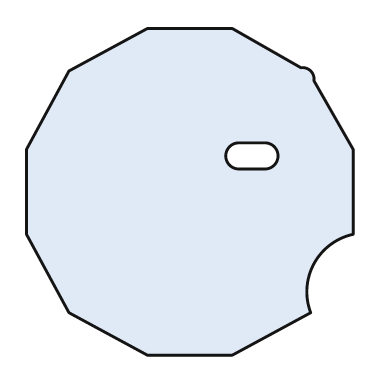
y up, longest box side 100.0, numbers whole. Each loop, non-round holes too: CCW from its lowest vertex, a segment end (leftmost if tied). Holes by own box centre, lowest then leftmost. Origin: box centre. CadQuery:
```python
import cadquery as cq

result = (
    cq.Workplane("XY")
    .moveTo(-13.0, -50.0)
    .lineTo(13.0, -50.0)
    .lineTo(37.0, -37.0)
    .threePointArc((38.0, -22.0), (50.0, -13.0))
    .lineTo(50.0, 13.0)
    .lineTo(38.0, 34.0)
    .threePointArc((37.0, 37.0), (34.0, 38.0))
    .lineTo(13.0, 50.0)
    .lineTo(-13.0, 50.0)
    .lineTo(-37.0, 37.0)
    .lineTo(-50.0, 13.0)
    .lineTo(-50.0, -13.0)
    .lineTo(-37.0, -37.0)
    .close()
    .moveTo(15.0, 7.0)
    .lineTo(23.0, 7.0)
    .threePointArc((27.0, 11.0), (23.0, 15.0))
    .lineTo(15.0, 15.0)
    .threePointArc((11.0, 11.0), (15.0, 7.0))
    .close()
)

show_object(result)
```